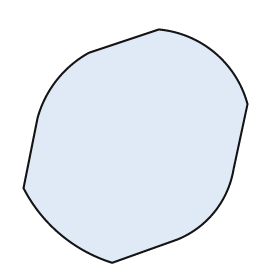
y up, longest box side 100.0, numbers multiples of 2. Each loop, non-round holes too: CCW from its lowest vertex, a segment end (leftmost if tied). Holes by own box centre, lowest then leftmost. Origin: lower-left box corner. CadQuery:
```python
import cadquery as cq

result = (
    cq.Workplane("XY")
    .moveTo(38.0, 0.0)
    .lineTo(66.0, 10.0)
    .threePointArc((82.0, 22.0), (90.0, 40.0))
    .lineTo(96.0, 68.0)
    .threePointArc((82.0, 90.0), (58.0, 100.0))
    .lineTo(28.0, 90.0)
    .threePointArc((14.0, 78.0), (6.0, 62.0))
    .lineTo(0.0, 32.0)
    .threePointArc((16.0, 12.0), (38.0, 0.0))
    .close()
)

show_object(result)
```